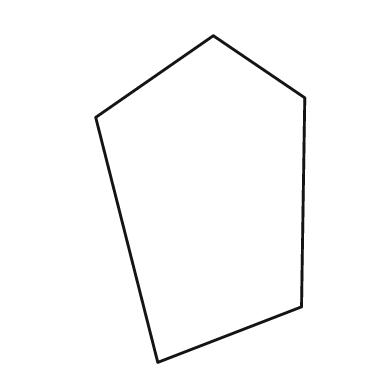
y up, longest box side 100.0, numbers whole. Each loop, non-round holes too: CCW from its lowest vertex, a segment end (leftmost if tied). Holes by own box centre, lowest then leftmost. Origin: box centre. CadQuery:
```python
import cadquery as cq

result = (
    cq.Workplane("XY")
    .moveTo(-13.0, -50.0)
    .lineTo(31.0, -33.0)
    .lineTo(32.0, 31.0)
    .lineTo(4.0, 50.0)
    .lineTo(-32.0, 25.0)
    .close()
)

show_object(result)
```